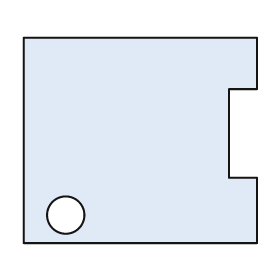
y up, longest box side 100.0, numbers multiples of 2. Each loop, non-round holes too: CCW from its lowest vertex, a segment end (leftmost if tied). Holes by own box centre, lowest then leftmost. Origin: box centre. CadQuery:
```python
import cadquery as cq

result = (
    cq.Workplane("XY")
    .moveTo(-50.0, -44.0)
    .lineTo(50.0, -44.0)
    .lineTo(50.0, -16.0)
    .lineTo(38.0, -16.0)
    .lineTo(38.0, 22.0)
    .lineTo(50.0, 22.0)
    .lineTo(50.0, 44.0)
    .lineTo(-50.0, 44.0)
    .close()
    .moveTo(-32.0, -32.0)
    .circle(8.0)
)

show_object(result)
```